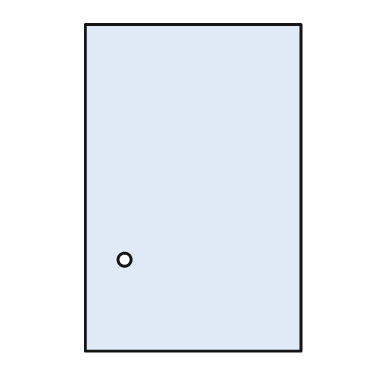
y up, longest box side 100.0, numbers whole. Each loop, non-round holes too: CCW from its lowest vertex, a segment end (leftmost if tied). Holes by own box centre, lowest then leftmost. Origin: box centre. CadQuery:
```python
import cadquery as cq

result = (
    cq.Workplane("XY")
    .moveTo(-33.0, -50.0)
    .lineTo(33.0, -50.0)
    .lineTo(33.0, 50.0)
    .lineTo(-33.0, 50.0)
    .close()
    .moveTo(-21.0, -22.0)
    .circle(2.0)
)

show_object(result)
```